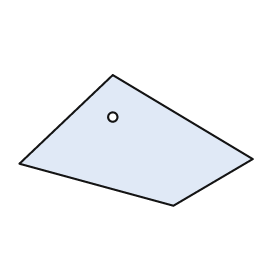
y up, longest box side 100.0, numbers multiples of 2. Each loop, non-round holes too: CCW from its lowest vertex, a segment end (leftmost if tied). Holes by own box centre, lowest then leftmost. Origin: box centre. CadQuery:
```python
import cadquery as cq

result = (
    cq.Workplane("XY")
    .moveTo(16.0, -28.0)
    .lineTo(50.0, -8.0)
    .lineTo(-10.0, 28.0)
    .lineTo(-50.0, -10.0)
    .close()
    .moveTo(-10.0, 10.0)
    .circle(2.0)
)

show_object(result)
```